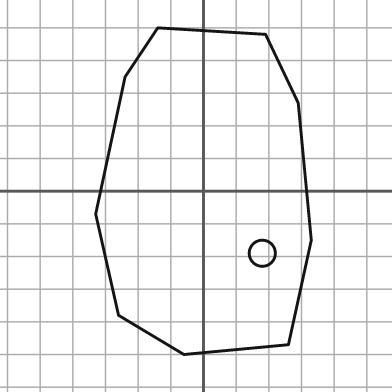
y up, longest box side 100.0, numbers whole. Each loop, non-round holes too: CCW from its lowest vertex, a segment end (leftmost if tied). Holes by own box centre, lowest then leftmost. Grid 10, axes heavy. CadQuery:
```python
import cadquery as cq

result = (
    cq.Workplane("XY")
    .moveTo(-6.0, -50.0)
    .lineTo(26.0, -47.0)
    .lineTo(33.0, -15.0)
    .lineTo(29.0, 27.0)
    .lineTo(19.0, 48.0)
    .lineTo(-14.0, 50.0)
    .lineTo(-24.0, 35.0)
    .lineTo(-33.0, -7.0)
    .lineTo(-26.0, -38.0)
    .close()
    .moveTo(18.0, -19.0)
    .circle(4.0)
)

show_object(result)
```